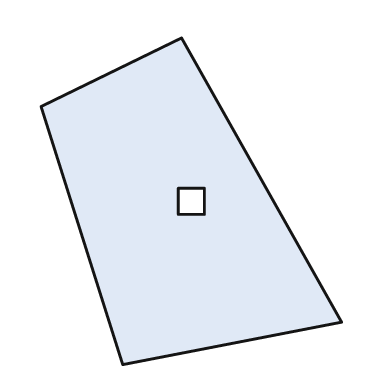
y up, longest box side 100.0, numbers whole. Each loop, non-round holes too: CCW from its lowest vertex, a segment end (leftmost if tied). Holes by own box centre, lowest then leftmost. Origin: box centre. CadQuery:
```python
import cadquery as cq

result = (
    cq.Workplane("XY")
    .moveTo(-21.0, -50.0)
    .lineTo(46.0, -37.0)
    .lineTo(-3.0, 50.0)
    .lineTo(-46.0, 29.0)
    .close()
    .moveTo(-4.0, -4.0)
    .lineTo(4.0, -4.0)
    .lineTo(4.0, 4.0)
    .lineTo(-4.0, 4.0)
    .close()
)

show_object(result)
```